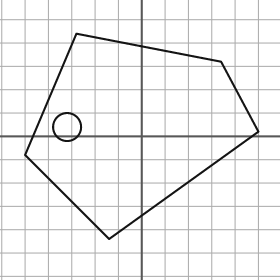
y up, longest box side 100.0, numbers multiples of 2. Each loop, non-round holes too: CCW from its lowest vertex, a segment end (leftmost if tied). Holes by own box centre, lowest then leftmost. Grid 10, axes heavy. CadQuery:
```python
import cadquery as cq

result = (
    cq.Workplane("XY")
    .moveTo(-14.0, -44.0)
    .lineTo(50.0, 2.0)
    .lineTo(34.0, 32.0)
    .lineTo(-28.0, 44.0)
    .lineTo(-50.0, -8.0)
    .close()
    .moveTo(-32.0, 4.0)
    .circle(6.0)
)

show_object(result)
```